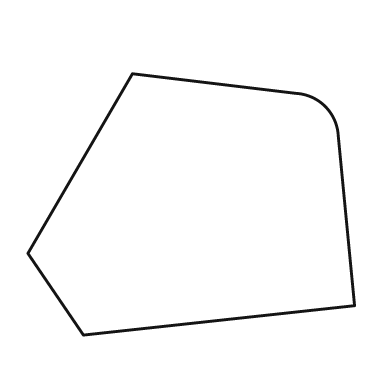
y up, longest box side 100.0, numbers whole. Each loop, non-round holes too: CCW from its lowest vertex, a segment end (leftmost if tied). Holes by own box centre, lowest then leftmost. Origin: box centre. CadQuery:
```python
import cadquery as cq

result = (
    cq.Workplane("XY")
    .moveTo(-33.0, -40.0)
    .lineTo(50.0, -31.0)
    .lineTo(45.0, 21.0)
    .threePointArc((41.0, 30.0), (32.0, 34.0))
    .lineTo(-18.0, 40.0)
    .lineTo(-50.0, -15.0)
    .close()
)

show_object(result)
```